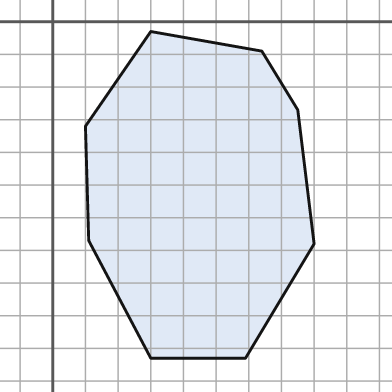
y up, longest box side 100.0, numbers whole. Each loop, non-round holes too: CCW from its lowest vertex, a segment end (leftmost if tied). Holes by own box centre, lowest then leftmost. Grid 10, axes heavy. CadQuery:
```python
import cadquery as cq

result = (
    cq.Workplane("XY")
    .moveTo(30.0, -103.0)
    .lineTo(59.0, -103.0)
    .lineTo(80.0, -68.0)
    .lineTo(75.0, -27.0)
    .lineTo(64.0, -9.0)
    .lineTo(30.0, -3.0)
    .lineTo(10.0, -32.0)
    .lineTo(11.0, -67.0)
    .close()
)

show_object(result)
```